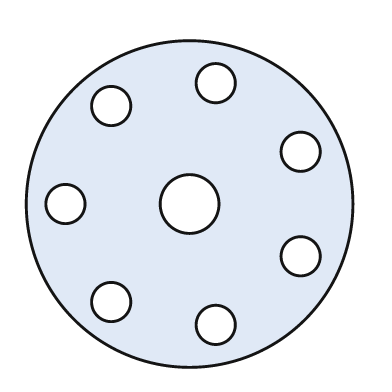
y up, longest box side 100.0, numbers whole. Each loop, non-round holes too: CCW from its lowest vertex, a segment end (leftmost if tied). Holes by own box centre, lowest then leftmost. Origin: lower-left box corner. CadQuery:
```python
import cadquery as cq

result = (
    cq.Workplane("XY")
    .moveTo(50.0, 50.0)
    .circle(50.0)
    .moveTo(58.0, 13.0)
    .circle(6.0)
    .moveTo(26.0, 20.0)
    .circle(6.0)
    .moveTo(84.0, 34.0)
    .circle(6.0)
    .moveTo(12.0, 50.0)
    .circle(6.0)
    .moveTo(50.0, 50.0)
    .circle(9.0)
    .moveTo(84.0, 66.0)
    .circle(6.0)
    .moveTo(26.0, 80.0)
    .circle(6.0)
    .moveTo(58.0, 87.0)
    .circle(6.0)
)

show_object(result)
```